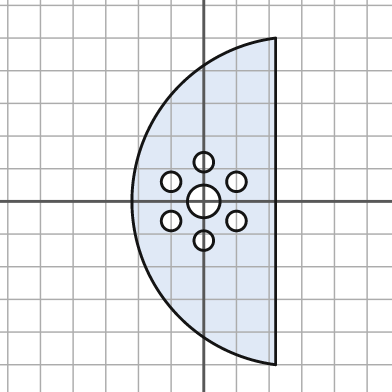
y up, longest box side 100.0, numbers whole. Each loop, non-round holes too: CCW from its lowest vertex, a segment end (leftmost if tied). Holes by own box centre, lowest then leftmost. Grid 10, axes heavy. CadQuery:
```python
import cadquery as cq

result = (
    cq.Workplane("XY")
    .moveTo(22.0, -50.0)
    .lineTo(22.0, 50.0)
    .threePointArc((-22.0, 0.0), (22.0, -50.0))
    .close()
    .moveTo(0.0, -12.0)
    .circle(3.0)
    .moveTo(-10.0, -6.0)
    .circle(3.0)
    .moveTo(10.0, -6.0)
    .circle(3.0)
    .moveTo(0.0, 0.0)
    .circle(5.0)
    .moveTo(-10.0, 6.0)
    .circle(3.0)
    .moveTo(10.0, 6.0)
    .circle(3.0)
    .moveTo(0.0, 12.0)
    .circle(3.0)
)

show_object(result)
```